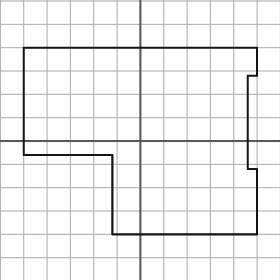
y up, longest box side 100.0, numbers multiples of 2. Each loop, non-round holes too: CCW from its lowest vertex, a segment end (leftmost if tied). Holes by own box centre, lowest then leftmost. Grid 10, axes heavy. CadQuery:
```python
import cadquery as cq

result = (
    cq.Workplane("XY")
    .moveTo(-12.0, -40.0)
    .lineTo(50.0, -40.0)
    .lineTo(50.0, -12.0)
    .lineTo(46.0, -12.0)
    .lineTo(46.0, 28.0)
    .lineTo(50.0, 28.0)
    .lineTo(50.0, 40.0)
    .lineTo(-50.0, 40.0)
    .lineTo(-50.0, -6.0)
    .lineTo(-12.0, -6.0)
    .close()
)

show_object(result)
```